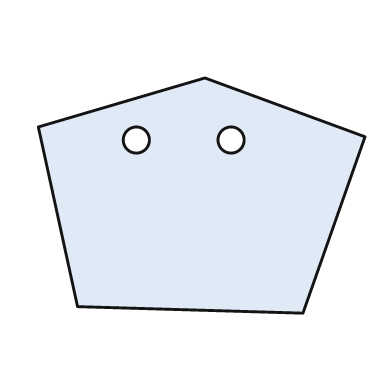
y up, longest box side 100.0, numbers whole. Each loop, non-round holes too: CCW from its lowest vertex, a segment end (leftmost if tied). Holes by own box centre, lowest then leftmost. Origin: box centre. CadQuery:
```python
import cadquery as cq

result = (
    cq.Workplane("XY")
    .moveTo(31.0, -36.0)
    .lineTo(50.0, 18.0)
    .lineTo(1.0, 36.0)
    .lineTo(-50.0, 21.0)
    .lineTo(-38.0, -34.0)
    .close()
    .moveTo(-20.0, 17.0)
    .circle(4.0)
    .moveTo(9.0, 17.0)
    .circle(4.0)
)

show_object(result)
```